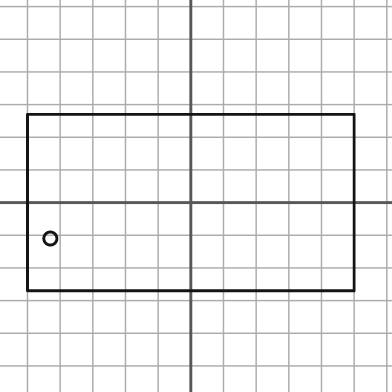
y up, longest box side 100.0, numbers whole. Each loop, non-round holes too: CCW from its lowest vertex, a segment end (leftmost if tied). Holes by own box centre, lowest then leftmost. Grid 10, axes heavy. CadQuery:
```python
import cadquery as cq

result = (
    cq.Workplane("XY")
    .moveTo(-50.0, -27.0)
    .lineTo(50.0, -27.0)
    .lineTo(50.0, 27.0)
    .lineTo(-50.0, 27.0)
    .close()
    .moveTo(-43.0, -11.0)
    .circle(2.0)
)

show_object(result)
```